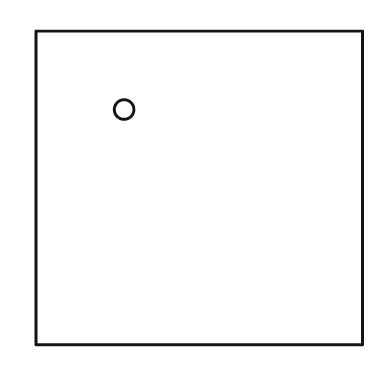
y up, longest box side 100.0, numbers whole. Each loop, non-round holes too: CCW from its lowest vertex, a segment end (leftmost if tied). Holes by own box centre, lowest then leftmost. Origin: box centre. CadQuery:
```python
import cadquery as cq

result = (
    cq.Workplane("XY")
    .moveTo(-50.0, -48.0)
    .lineTo(50.0, -48.0)
    .lineTo(50.0, 48.0)
    .lineTo(-50.0, 48.0)
    .close()
    .moveTo(-23.0, 24.0)
    .circle(3.0)
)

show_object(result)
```